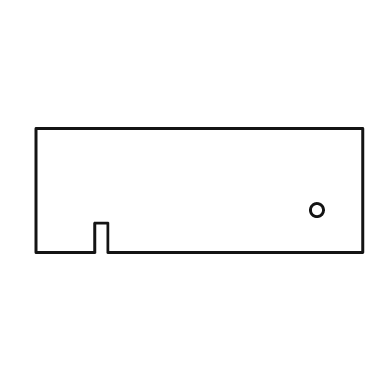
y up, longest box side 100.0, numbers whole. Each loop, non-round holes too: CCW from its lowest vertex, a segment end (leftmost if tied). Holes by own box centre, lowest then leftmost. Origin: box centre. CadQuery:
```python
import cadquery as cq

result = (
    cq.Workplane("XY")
    .moveTo(-50.0, -19.0)
    .lineTo(-32.0, -19.0)
    .lineTo(-32.0, -10.0)
    .lineTo(-28.0, -10.0)
    .lineTo(-28.0, -19.0)
    .lineTo(50.0, -19.0)
    .lineTo(50.0, 19.0)
    .lineTo(-50.0, 19.0)
    .close()
    .moveTo(36.0, -6.0)
    .circle(2.0)
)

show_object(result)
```